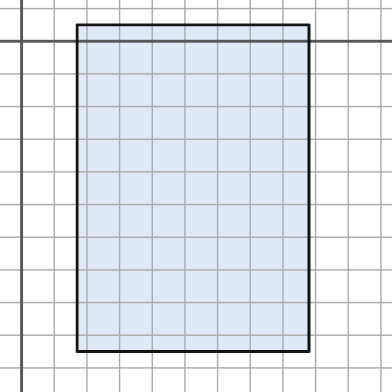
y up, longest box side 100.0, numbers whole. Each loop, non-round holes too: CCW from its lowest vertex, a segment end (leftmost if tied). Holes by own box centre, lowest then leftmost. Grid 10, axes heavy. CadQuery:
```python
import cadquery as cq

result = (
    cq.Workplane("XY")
    .moveTo(17.0, -95.0)
    .lineTo(88.0, -95.0)
    .lineTo(88.0, 5.0)
    .lineTo(17.0, 5.0)
    .close()
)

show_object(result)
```